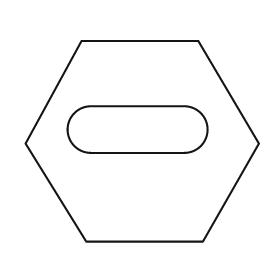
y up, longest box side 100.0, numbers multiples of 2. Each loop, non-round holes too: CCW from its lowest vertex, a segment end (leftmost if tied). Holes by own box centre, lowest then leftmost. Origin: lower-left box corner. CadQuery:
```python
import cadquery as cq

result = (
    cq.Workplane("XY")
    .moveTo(26.0, 0.0)
    .lineTo(76.0, 0.0)
    .lineTo(100.0, 42.0)
    .lineTo(74.0, 86.0)
    .lineTo(24.0, 86.0)
    .lineTo(0.0, 42.0)
    .close()
    .moveTo(28.0, 38.0)
    .lineTo(68.0, 38.0)
    .threePointArc((78.0, 48.0), (68.0, 58.0))
    .lineTo(28.0, 58.0)
    .threePointArc((18.0, 48.0), (28.0, 38.0))
    .close()
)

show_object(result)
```